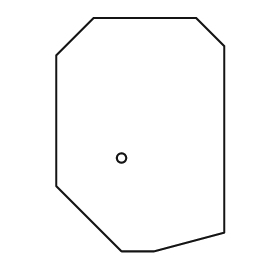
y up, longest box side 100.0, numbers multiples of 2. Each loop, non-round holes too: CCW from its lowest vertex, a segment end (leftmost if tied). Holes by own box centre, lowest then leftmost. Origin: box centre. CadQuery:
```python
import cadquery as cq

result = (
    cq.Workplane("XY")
    .moveTo(-8.0, -50.0)
    .lineTo(6.0, -50.0)
    .lineTo(36.0, -42.0)
    .lineTo(36.0, 38.0)
    .lineTo(24.0, 50.0)
    .lineTo(-20.0, 50.0)
    .lineTo(-36.0, 34.0)
    .lineTo(-36.0, -22.0)
    .close()
    .moveTo(-8.0, -10.0)
    .circle(2.0)
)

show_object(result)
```